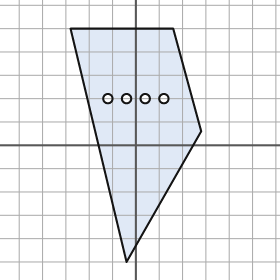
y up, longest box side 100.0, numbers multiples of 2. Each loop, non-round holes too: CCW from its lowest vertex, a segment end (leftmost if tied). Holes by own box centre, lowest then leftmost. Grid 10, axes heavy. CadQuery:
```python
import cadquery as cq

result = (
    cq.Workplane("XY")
    .moveTo(-4.0, -50.0)
    .lineTo(28.0, 6.0)
    .lineTo(16.0, 50.0)
    .lineTo(-28.0, 50.0)
    .close()
    .moveTo(-12.0, 20.0)
    .circle(2.0)
    .moveTo(-4.0, 20.0)
    .circle(2.0)
    .moveTo(4.0, 20.0)
    .circle(2.0)
    .moveTo(12.0, 20.0)
    .circle(2.0)
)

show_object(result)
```